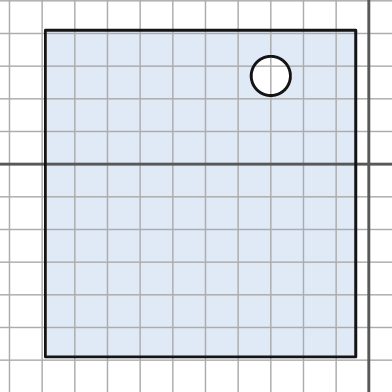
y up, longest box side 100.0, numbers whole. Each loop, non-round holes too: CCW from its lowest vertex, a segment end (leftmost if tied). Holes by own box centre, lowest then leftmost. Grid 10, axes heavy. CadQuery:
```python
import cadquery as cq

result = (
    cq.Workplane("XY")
    .moveTo(-99.0, -59.0)
    .lineTo(-4.0, -59.0)
    .lineTo(-4.0, 41.0)
    .lineTo(-99.0, 41.0)
    .close()
    .moveTo(-30.0, 27.0)
    .circle(6.0)
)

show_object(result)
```